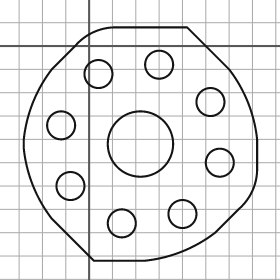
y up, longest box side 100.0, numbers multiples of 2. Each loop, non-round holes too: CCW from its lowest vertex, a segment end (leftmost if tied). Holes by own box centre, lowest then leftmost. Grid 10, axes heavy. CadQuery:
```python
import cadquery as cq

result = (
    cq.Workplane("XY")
    .moveTo(2.0, -92.0)
    .lineTo(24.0, -92.0)
    .threePointArc((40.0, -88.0), (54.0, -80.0))
    .lineTo(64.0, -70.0)
    .threePointArc((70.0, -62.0), (72.0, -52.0))
    .lineTo(72.0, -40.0)
    .threePointArc((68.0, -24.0), (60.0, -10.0))
    .lineTo(42.0, 8.0)
    .lineTo(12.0, 8.0)
    .threePointArc((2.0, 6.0), (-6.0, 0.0))
    .lineTo(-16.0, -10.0)
    .threePointArc((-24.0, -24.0), (-28.0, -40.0))
    .lineTo(-28.0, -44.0)
    .threePointArc((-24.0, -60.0), (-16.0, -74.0))
    .close()
    .moveTo(14.0, -76.0)
    .circle(6.0)
    .moveTo(40.0, -72.0)
    .circle(6.0)
    .moveTo(-8.0, -60.0)
    .circle(6.0)
    .moveTo(56.0, -50.0)
    .circle(6.0)
    .moveTo(22.0, -42.0)
    .circle(14.0)
    .moveTo(-12.0, -34.0)
    .circle(6.0)
    .moveTo(52.0, -24.0)
    .circle(6.0)
    .moveTo(4.0, -12.0)
    .circle(6.0)
    .moveTo(30.0, -8.0)
    .circle(6.0)
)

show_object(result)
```